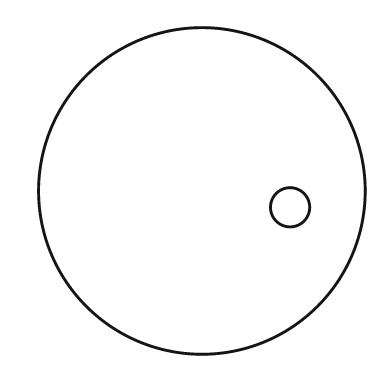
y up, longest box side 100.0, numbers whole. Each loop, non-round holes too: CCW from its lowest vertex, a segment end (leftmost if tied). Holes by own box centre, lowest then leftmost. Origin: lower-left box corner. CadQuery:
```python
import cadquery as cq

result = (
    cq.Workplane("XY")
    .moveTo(50.0, 50.0)
    .circle(50.0)
    .moveTo(77.0, 45.0)
    .circle(6.0)
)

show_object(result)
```